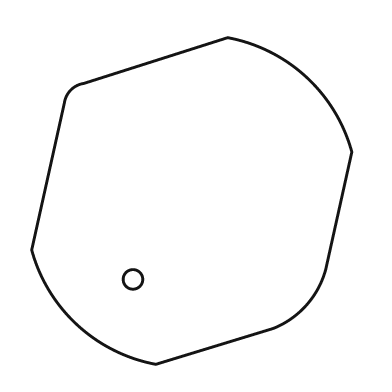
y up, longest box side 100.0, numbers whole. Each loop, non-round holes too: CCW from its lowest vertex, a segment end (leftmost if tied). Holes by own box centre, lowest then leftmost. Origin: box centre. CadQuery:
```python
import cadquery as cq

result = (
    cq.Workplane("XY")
    .moveTo(-11.0, -50.0)
    .lineTo(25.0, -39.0)
    .threePointArc((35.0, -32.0), (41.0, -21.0))
    .lineTo(49.0, 15.0)
    .threePointArc((35.0, 38.0), (11.0, 50.0))
    .lineTo(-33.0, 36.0)
    .threePointArc((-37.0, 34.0), (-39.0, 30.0))
    .lineTo(-49.0, -15.0)
    .threePointArc((-35.0, -38.0), (-11.0, -50.0))
    .close()
    .moveTo(-18.0, -24.0)
    .circle(3.0)
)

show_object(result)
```